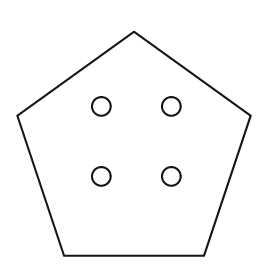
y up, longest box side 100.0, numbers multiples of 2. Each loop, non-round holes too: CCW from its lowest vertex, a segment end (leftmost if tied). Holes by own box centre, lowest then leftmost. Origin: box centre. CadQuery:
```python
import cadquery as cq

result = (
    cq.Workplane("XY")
    .moveTo(-30.0, -48.0)
    .lineTo(30.0, -48.0)
    .lineTo(50.0, 12.0)
    .lineTo(0.0, 48.0)
    .lineTo(-50.0, 12.0)
    .close()
    .moveTo(-14.0, -14.0)
    .circle(4.0)
    .moveTo(16.0, -14.0)
    .circle(4.0)
    .moveTo(-14.0, 16.0)
    .circle(4.0)
    .moveTo(16.0, 16.0)
    .circle(4.0)
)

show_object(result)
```